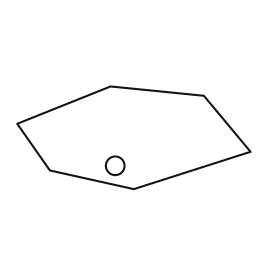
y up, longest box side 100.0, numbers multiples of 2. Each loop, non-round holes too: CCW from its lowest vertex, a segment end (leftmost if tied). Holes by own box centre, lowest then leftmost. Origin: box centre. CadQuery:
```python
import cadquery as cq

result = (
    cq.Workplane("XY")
    .moveTo(0.0, -22.0)
    .lineTo(50.0, -6.0)
    .lineTo(30.0, 18.0)
    .lineTo(-10.0, 22.0)
    .lineTo(-50.0, 6.0)
    .lineTo(-36.0, -14.0)
    .close()
    .moveTo(-8.0, -12.0)
    .circle(4.0)
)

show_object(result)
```